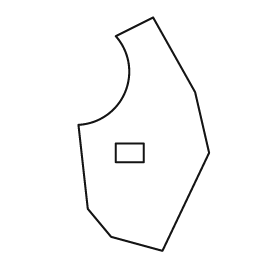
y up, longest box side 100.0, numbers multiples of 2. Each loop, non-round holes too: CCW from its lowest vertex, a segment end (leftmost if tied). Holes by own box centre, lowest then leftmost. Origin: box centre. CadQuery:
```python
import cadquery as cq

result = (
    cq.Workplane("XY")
    .moveTo(8.0, -50.0)
    .lineTo(28.0, -8.0)
    .lineTo(22.0, 18.0)
    .lineTo(4.0, 50.0)
    .lineTo(-12.0, 42.0)
    .threePointArc((-8.0, 18.0), (-28.0, 4.0))
    .lineTo(-24.0, -32.0)
    .lineTo(-14.0, -44.0)
    .close()
    .moveTo(-12.0, -12.0)
    .lineTo(0.0, -12.0)
    .lineTo(0.0, -4.0)
    .lineTo(-12.0, -4.0)
    .close()
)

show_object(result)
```